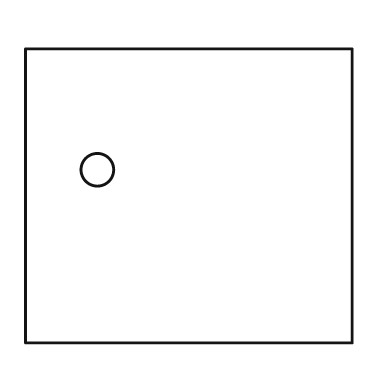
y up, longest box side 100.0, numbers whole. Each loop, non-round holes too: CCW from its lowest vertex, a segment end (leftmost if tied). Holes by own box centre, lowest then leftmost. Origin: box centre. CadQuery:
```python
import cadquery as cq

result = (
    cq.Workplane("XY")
    .moveTo(-50.0, -45.0)
    .lineTo(50.0, -45.0)
    .lineTo(50.0, 45.0)
    .lineTo(-50.0, 45.0)
    .close()
    .moveTo(-28.0, 8.0)
    .circle(5.0)
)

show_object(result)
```